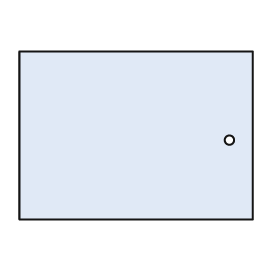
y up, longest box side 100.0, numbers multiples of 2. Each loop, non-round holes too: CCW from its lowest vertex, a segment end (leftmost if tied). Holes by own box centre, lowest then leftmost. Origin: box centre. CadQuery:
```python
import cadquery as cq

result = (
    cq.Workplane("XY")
    .moveTo(-50.0, -36.0)
    .lineTo(50.0, -36.0)
    .lineTo(50.0, 36.0)
    .lineTo(-50.0, 36.0)
    .close()
    .moveTo(40.0, -2.0)
    .circle(2.0)
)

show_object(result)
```